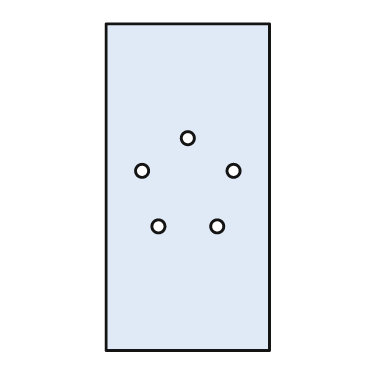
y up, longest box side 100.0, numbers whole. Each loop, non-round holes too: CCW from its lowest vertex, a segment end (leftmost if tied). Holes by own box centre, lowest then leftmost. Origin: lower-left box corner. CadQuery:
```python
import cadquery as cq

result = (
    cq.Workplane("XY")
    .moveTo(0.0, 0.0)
    .lineTo(50.0, 0.0)
    .lineTo(50.0, 100.0)
    .lineTo(0.0, 100.0)
    .close()
    .moveTo(16.0, 38.0)
    .circle(2.0)
    .moveTo(34.0, 38.0)
    .circle(2.0)
    .moveTo(11.0, 55.0)
    .circle(2.0)
    .moveTo(39.0, 55.0)
    .circle(2.0)
    .moveTo(25.0, 65.0)
    .circle(2.0)
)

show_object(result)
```